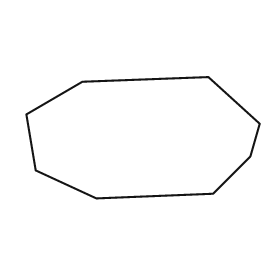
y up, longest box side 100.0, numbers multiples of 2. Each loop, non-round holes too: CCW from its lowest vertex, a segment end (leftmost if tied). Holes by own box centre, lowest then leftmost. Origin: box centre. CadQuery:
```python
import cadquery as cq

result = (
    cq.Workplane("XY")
    .moveTo(-20.0, -26.0)
    .lineTo(30.0, -24.0)
    .lineTo(46.0, -8.0)
    .lineTo(50.0, 6.0)
    .lineTo(28.0, 26.0)
    .lineTo(-26.0, 24.0)
    .lineTo(-50.0, 10.0)
    .lineTo(-46.0, -14.0)
    .close()
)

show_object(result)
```